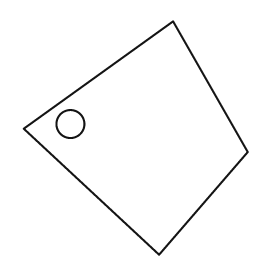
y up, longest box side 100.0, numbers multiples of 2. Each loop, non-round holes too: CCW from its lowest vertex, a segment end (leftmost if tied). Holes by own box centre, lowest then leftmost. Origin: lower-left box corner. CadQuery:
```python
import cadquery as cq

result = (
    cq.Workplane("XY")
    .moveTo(58.0, 0.0)
    .lineTo(96.0, 44.0)
    .lineTo(64.0, 100.0)
    .lineTo(0.0, 54.0)
    .close()
    .moveTo(20.0, 56.0)
    .circle(6.0)
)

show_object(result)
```